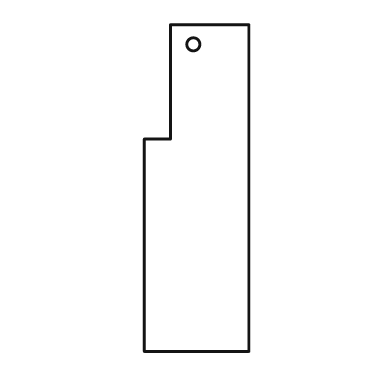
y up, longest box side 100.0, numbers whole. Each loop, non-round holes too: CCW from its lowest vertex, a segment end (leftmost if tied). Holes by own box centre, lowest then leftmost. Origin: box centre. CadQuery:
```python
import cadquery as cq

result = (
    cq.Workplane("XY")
    .moveTo(-16.0, -50.0)
    .lineTo(16.0, -50.0)
    .lineTo(16.0, 50.0)
    .lineTo(-8.0, 50.0)
    .lineTo(-8.0, 15.0)
    .lineTo(-16.0, 15.0)
    .close()
    .moveTo(-1.0, 44.0)
    .circle(2.0)
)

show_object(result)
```